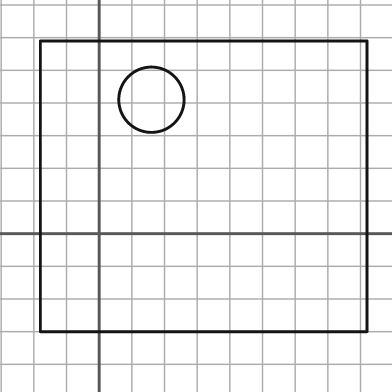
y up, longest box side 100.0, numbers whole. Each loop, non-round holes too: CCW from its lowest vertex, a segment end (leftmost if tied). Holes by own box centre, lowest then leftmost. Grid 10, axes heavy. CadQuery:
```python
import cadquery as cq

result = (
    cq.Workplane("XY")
    .moveTo(-18.0, -30.0)
    .lineTo(82.0, -30.0)
    .lineTo(82.0, 59.0)
    .lineTo(-18.0, 59.0)
    .close()
    .moveTo(16.0, 41.0)
    .circle(10.0)
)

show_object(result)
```